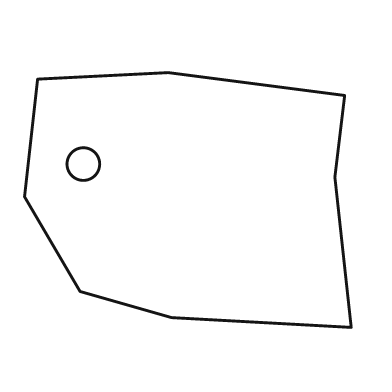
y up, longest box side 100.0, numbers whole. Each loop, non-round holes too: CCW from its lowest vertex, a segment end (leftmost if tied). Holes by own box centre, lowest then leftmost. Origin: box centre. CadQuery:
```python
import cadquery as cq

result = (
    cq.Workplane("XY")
    .moveTo(50.0, -39.0)
    .lineTo(45.0, 7.0)
    .lineTo(48.0, 32.0)
    .lineTo(-6.0, 39.0)
    .lineTo(-46.0, 37.0)
    .lineTo(-50.0, 1.0)
    .lineTo(-33.0, -28.0)
    .lineTo(-5.0, -36.0)
    .close()
    .moveTo(-32.0, 11.0)
    .circle(5.0)
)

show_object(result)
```